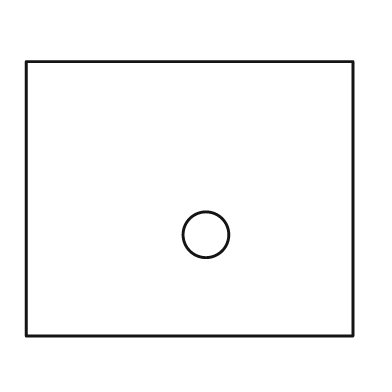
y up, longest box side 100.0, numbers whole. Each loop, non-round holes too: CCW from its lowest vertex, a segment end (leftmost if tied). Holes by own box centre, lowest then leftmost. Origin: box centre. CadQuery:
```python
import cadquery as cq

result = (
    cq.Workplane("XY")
    .moveTo(-50.0, -42.0)
    .lineTo(50.0, -42.0)
    .lineTo(50.0, 42.0)
    .lineTo(-50.0, 42.0)
    .close()
    .moveTo(5.0, -11.0)
    .circle(7.0)
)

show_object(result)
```